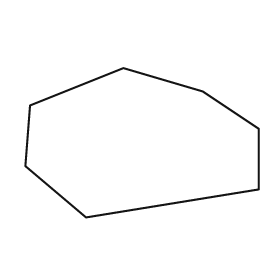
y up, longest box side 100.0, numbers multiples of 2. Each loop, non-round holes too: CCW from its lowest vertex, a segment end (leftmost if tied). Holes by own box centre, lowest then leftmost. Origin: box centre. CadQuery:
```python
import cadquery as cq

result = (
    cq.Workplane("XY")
    .moveTo(-24.0, -32.0)
    .lineTo(50.0, -20.0)
    .lineTo(50.0, 6.0)
    .lineTo(26.0, 22.0)
    .lineTo(-8.0, 32.0)
    .lineTo(-48.0, 16.0)
    .lineTo(-50.0, -10.0)
    .close()
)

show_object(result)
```